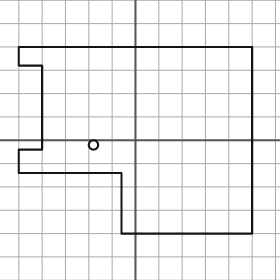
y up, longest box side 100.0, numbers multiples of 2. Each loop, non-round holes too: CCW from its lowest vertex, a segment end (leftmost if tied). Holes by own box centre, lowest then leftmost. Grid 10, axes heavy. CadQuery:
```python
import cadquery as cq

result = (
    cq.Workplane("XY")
    .moveTo(-6.0, -40.0)
    .lineTo(50.0, -40.0)
    .lineTo(50.0, 40.0)
    .lineTo(-50.0, 40.0)
    .lineTo(-50.0, 32.0)
    .lineTo(-40.0, 32.0)
    .lineTo(-40.0, -4.0)
    .lineTo(-50.0, -4.0)
    .lineTo(-50.0, -14.0)
    .lineTo(-6.0, -14.0)
    .close()
    .moveTo(-18.0, -2.0)
    .circle(2.0)
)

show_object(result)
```